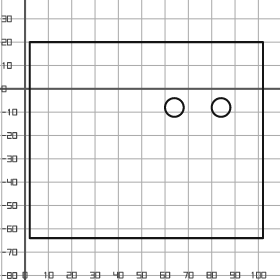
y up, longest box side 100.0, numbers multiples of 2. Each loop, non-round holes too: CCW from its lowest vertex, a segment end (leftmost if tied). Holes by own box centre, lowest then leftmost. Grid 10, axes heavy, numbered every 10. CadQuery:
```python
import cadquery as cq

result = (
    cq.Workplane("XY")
    .moveTo(2.0, -64.0)
    .lineTo(102.0, -64.0)
    .lineTo(102.0, 20.0)
    .lineTo(2.0, 20.0)
    .close()
    .moveTo(64.0, -8.0)
    .circle(4.0)
    .moveTo(84.0, -8.0)
    .circle(4.0)
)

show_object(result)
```